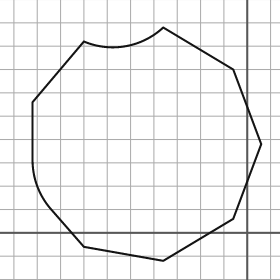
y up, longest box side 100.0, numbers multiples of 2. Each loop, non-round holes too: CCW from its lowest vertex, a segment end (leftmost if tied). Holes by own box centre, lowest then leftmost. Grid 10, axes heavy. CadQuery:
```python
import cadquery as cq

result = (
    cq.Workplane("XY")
    .moveTo(-36.0, -12.0)
    .lineTo(-6.0, 6.0)
    .lineTo(6.0, 38.0)
    .lineTo(-6.0, 70.0)
    .lineTo(-36.0, 88.0)
    .threePointArc((-52.0, 80.0), (-70.0, 82.0))
    .lineTo(-92.0, 56.0)
    .lineTo(-92.0, 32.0)
    .threePointArc((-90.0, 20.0), (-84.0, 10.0))
    .lineTo(-70.0, -6.0)
    .close()
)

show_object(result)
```